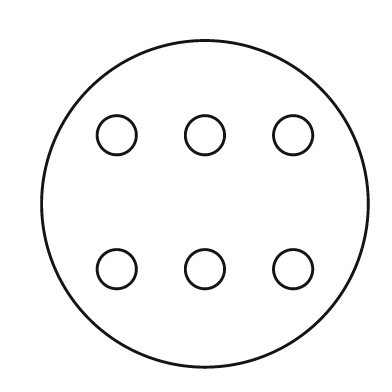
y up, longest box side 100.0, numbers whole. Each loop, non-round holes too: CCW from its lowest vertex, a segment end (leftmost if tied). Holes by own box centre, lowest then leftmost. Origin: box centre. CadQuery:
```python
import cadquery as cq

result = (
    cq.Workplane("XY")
    .moveTo(0.0, 0.0)
    .circle(50.0)
    .moveTo(-27.0, -20.0)
    .circle(6.0)
    .moveTo(0.0, -20.0)
    .circle(6.0)
    .moveTo(27.0, -20.0)
    .circle(6.0)
    .moveTo(-27.0, 21.0)
    .circle(6.0)
    .moveTo(0.0, 21.0)
    .circle(6.0)
    .moveTo(27.0, 21.0)
    .circle(6.0)
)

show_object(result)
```